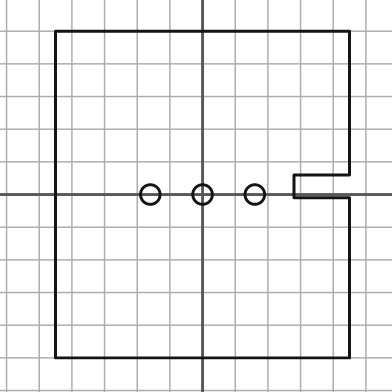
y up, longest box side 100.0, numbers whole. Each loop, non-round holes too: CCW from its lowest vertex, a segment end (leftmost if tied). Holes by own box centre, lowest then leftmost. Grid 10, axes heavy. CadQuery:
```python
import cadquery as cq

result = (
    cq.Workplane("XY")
    .moveTo(-45.0, -50.0)
    .lineTo(45.0, -50.0)
    .lineTo(45.0, -1.0)
    .lineTo(28.0, -1.0)
    .lineTo(28.0, 6.0)
    .lineTo(45.0, 6.0)
    .lineTo(45.0, 50.0)
    .lineTo(-45.0, 50.0)
    .close()
    .moveTo(-16.0, 0.0)
    .circle(3.0)
    .moveTo(0.0, 0.0)
    .circle(3.0)
    .moveTo(16.0, 0.0)
    .circle(3.0)
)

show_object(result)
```